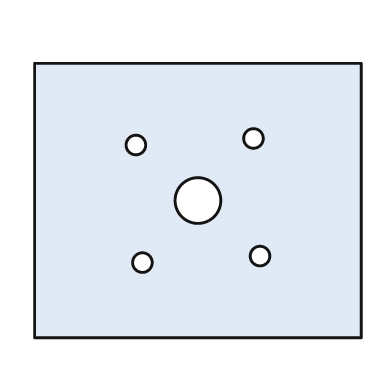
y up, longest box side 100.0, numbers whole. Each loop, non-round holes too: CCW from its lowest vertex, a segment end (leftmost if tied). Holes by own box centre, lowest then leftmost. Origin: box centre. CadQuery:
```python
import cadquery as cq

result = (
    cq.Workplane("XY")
    .moveTo(-50.0, -42.0)
    .lineTo(50.0, -42.0)
    .lineTo(50.0, 42.0)
    .lineTo(-50.0, 42.0)
    .close()
    .moveTo(-17.0, -19.0)
    .circle(3.0)
    .moveTo(19.0, -17.0)
    .circle(3.0)
    .moveTo(0.0, 0.0)
    .circle(7.0)
    .moveTo(-19.0, 17.0)
    .circle(3.0)
    .moveTo(17.0, 19.0)
    .circle(3.0)
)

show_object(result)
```